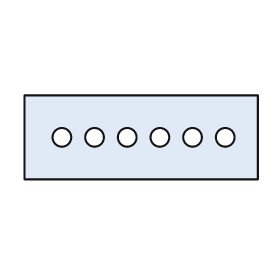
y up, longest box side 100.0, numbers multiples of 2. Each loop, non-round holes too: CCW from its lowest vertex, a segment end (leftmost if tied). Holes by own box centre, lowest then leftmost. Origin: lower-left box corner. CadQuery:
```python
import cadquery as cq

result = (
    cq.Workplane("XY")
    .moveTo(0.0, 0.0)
    .lineTo(100.0, 0.0)
    .lineTo(100.0, 36.0)
    .lineTo(0.0, 36.0)
    .close()
    .moveTo(16.0, 18.0)
    .circle(4.0)
    .moveTo(30.0, 18.0)
    .circle(4.0)
    .moveTo(44.0, 18.0)
    .circle(4.0)
    .moveTo(58.0, 18.0)
    .circle(4.0)
    .moveTo(72.0, 18.0)
    .circle(4.0)
    .moveTo(86.0, 18.0)
    .circle(4.0)
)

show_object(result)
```